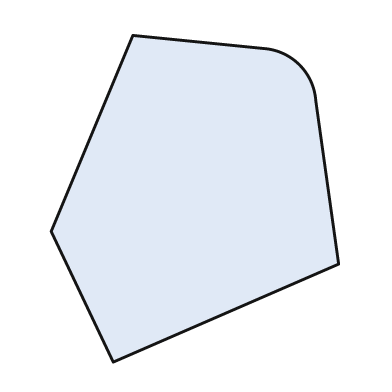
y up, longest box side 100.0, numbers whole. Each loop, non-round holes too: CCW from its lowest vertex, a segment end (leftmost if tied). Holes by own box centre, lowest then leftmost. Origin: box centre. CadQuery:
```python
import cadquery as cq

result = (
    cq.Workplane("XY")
    .moveTo(-25.0, -50.0)
    .lineTo(44.0, -20.0)
    .lineTo(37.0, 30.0)
    .threePointArc((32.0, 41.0), (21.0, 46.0))
    .lineTo(-19.0, 50.0)
    .lineTo(-44.0, -10.0)
    .close()
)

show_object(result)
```